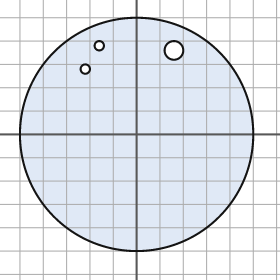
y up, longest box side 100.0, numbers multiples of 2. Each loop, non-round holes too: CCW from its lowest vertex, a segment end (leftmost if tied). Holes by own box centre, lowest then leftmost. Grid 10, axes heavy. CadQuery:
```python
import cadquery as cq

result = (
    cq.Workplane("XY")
    .moveTo(0.0, 0.0)
    .circle(50.0)
    .moveTo(-22.0, 28.0)
    .circle(2.0)
    .moveTo(16.0, 36.0)
    .circle(4.0)
    .moveTo(-16.0, 38.0)
    .circle(2.0)
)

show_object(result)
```